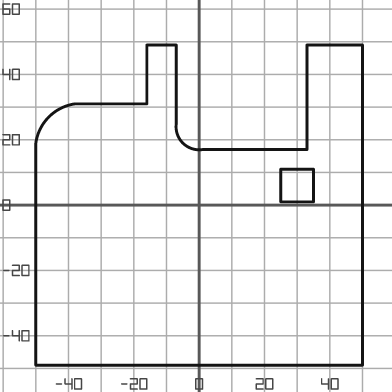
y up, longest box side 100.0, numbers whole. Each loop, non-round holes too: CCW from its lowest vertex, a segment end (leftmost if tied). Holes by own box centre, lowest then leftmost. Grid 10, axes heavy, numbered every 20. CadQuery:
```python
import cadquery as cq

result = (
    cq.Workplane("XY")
    .moveTo(-50.0, -49.0)
    .lineTo(50.0, -49.0)
    .lineTo(50.0, 49.0)
    .lineTo(33.0, 49.0)
    .lineTo(33.0, 17.0)
    .lineTo(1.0, 17.0)
    .threePointArc((-5.0, 19.0), (-7.0, 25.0))
    .lineTo(-7.0, 49.0)
    .lineTo(-16.0, 49.0)
    .lineTo(-16.0, 31.0)
    .lineTo(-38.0, 31.0)
    .threePointArc((-46.0, 27.0), (-50.0, 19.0))
    .close()
    .moveTo(25.0, 1.0)
    .lineTo(35.0, 1.0)
    .lineTo(35.0, 11.0)
    .lineTo(25.0, 11.0)
    .close()
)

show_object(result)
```